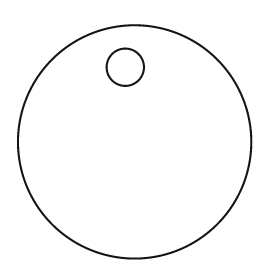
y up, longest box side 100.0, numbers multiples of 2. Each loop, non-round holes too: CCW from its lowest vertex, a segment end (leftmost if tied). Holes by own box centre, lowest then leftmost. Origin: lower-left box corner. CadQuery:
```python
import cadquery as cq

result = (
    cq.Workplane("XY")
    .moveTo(50.0, 50.0)
    .circle(50.0)
    .moveTo(46.0, 82.0)
    .circle(8.0)
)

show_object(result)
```